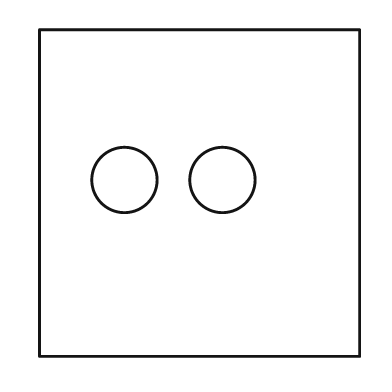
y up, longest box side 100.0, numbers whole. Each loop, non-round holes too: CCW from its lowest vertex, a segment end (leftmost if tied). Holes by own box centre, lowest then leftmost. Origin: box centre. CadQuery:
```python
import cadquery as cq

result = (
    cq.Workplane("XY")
    .moveTo(-49.0, -50.0)
    .lineTo(49.0, -50.0)
    .lineTo(49.0, 50.0)
    .lineTo(-49.0, 50.0)
    .close()
    .moveTo(-23.0, 4.0)
    .circle(10.0)
    .moveTo(7.0, 4.0)
    .circle(10.0)
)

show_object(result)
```